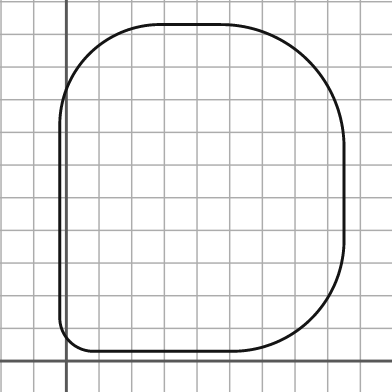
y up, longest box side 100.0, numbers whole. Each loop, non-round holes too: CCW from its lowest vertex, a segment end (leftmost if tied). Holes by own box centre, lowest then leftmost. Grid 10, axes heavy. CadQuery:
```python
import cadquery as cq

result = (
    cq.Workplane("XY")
    .moveTo(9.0, 3.0)
    .lineTo(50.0, 3.0)
    .threePointArc((75.0, 13.0), (85.0, 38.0))
    .lineTo(85.0, 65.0)
    .threePointArc((74.0, 92.0), (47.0, 103.0))
    .lineTo(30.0, 103.0)
    .threePointArc((7.0, 94.0), (-2.0, 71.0))
    .lineTo(-2.0, 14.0)
    .threePointArc((1.0, 6.0), (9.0, 3.0))
    .close()
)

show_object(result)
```